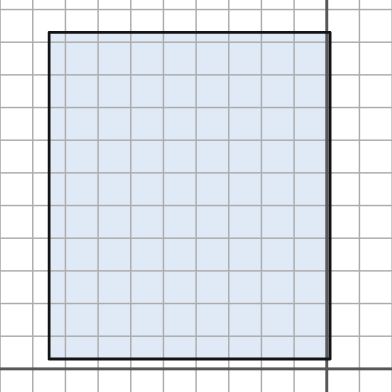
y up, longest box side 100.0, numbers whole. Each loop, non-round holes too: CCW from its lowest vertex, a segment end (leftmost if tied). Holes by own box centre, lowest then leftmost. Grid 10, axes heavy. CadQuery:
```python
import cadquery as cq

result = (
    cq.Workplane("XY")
    .moveTo(-85.0, 3.0)
    .lineTo(1.0, 3.0)
    .lineTo(1.0, 103.0)
    .lineTo(-85.0, 103.0)
    .close()
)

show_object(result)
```